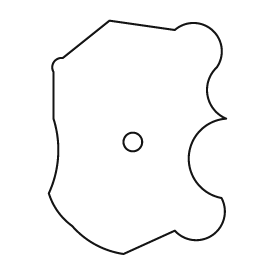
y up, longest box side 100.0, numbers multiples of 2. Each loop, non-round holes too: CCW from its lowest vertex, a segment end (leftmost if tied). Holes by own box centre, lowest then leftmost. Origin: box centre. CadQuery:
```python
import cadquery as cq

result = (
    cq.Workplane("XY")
    .moveTo(-6.0, -50.0)
    .lineTo(16.0, -40.0)
    .threePointArc((32.0, -42.0), (36.0, -26.0))
    .threePointArc((22.0, -8.0), (38.0, 8.0))
    .threePointArc((30.0, 18.0), (34.0, 30.0))
    .threePointArc((32.0, 46.0), (16.0, 46.0))
    .lineTo(-12.0, 50.0)
    .lineTo(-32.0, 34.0)
    .threePointArc((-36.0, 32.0), (-36.0, 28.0))
    .lineTo(-36.0, 8.0)
    .threePointArc((-34.0, -8.0), (-38.0, -24.0))
    .threePointArc((-34.0, -32.0), (-28.0, -38.0))
    .threePointArc((-18.0, -46.0), (-6.0, -50.0))
    .close()
    .moveTo(-2.0, -2.0)
    .circle(4.0)
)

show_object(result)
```